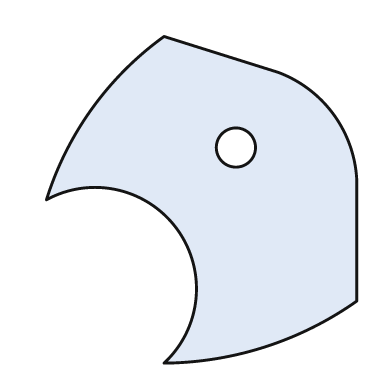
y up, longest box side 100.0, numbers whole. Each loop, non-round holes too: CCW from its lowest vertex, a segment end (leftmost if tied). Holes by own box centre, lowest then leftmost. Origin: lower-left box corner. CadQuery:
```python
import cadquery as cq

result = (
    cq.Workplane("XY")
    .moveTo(36.0, 0.0)
    .threePointArc((67.0, 5.0), (95.0, 19.0))
    .lineTo(95.0, 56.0)
    .threePointArc((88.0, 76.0), (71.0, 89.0))
    .lineTo(36.0, 100.0)
    .threePointArc((14.0, 78.0), (0.0, 50.0))
    .threePointArc((40.0, 41.0), (36.0, 0.0))
    .close()
    .moveTo(58.0, 66.0)
    .circle(6.0)
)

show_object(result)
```